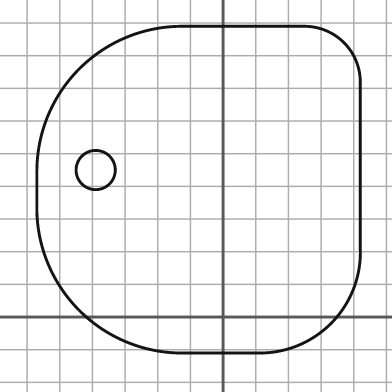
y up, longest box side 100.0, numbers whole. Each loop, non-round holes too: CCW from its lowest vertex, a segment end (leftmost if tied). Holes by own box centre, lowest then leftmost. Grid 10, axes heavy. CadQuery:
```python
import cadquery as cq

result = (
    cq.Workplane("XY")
    .moveTo(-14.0, -11.0)
    .lineTo(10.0, -11.0)
    .threePointArc((33.0, -2.0), (42.0, 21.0))
    .lineTo(42.0, 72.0)
    .threePointArc((37.0, 84.0), (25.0, 89.0))
    .lineTo(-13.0, 89.0)
    .threePointArc((-44.0, 76.0), (-57.0, 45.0))
    .lineTo(-57.0, 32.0)
    .threePointArc((-44.0, 2.0), (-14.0, -11.0))
    .close()
    .moveTo(-39.0, 45.0)
    .circle(6.0)
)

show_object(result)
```